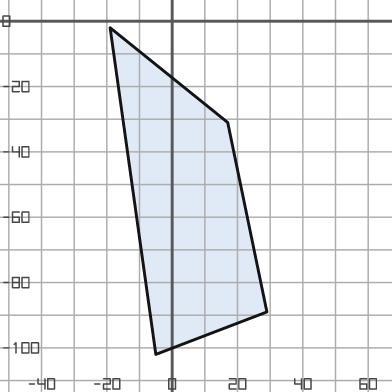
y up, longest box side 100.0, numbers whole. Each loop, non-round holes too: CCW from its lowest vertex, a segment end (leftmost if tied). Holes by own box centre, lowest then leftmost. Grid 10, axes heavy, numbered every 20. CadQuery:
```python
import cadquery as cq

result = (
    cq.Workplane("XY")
    .moveTo(-5.0, -102.0)
    .lineTo(29.0, -89.0)
    .lineTo(17.0, -31.0)
    .lineTo(-19.0, -2.0)
    .close()
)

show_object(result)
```